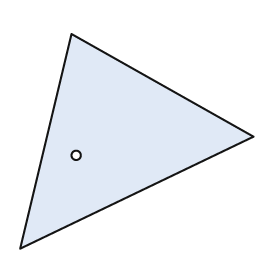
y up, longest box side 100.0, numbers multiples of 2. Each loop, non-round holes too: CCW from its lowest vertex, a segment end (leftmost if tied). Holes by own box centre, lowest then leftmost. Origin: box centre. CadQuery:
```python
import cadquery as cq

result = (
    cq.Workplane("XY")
    .moveTo(-50.0, -46.0)
    .lineTo(50.0, 2.0)
    .lineTo(-28.0, 46.0)
    .close()
    .moveTo(-26.0, -6.0)
    .circle(2.0)
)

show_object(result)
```